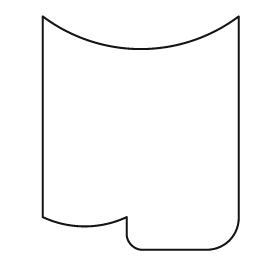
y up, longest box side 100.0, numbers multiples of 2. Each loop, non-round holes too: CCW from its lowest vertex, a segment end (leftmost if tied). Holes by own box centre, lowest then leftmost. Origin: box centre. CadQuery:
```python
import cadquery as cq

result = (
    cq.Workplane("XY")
    .moveTo(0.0, -50.0)
    .lineTo(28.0, -50.0)
    .threePointArc((38.0, -46.0), (42.0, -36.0))
    .lineTo(42.0, 50.0)
    .threePointArc((0.0, 36.0), (-42.0, 50.0))
    .lineTo(-42.0, -36.0)
    .threePointArc((-24.0, -40.0), (-6.0, -36.0))
    .lineTo(-6.0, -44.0)
    .threePointArc((-4.0, -48.0), (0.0, -50.0))
    .close()
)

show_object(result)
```